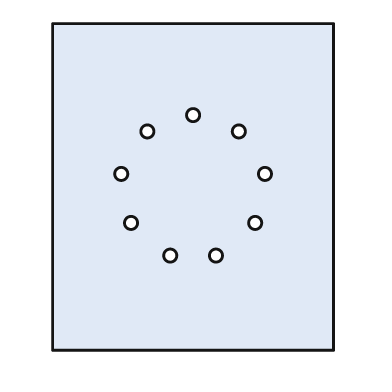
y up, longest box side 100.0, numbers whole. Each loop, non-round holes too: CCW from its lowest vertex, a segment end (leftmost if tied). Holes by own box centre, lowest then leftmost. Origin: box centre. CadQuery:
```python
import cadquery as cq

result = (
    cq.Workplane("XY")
    .moveTo(-43.0, -50.0)
    .lineTo(43.0, -50.0)
    .lineTo(43.0, 50.0)
    .lineTo(-43.0, 50.0)
    .close()
    .moveTo(-7.0, -21.0)
    .circle(2.0)
    .moveTo(7.0, -21.0)
    .circle(2.0)
    .moveTo(-19.0, -11.0)
    .circle(2.0)
    .moveTo(19.0, -11.0)
    .circle(2.0)
    .moveTo(-22.0, 4.0)
    .circle(2.0)
    .moveTo(22.0, 4.0)
    .circle(2.0)
    .moveTo(-14.0, 17.0)
    .circle(2.0)
    .moveTo(14.0, 17.0)
    .circle(2.0)
    .moveTo(0.0, 22.0)
    .circle(2.0)
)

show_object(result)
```